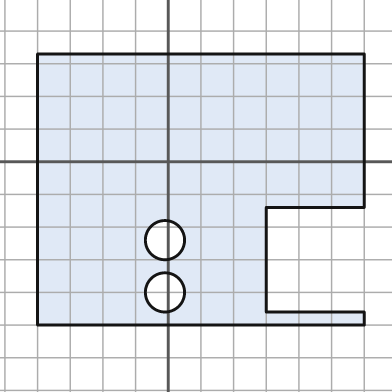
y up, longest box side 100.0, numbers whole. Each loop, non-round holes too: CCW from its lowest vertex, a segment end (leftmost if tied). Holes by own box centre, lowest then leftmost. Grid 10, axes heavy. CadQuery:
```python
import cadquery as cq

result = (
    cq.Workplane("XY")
    .moveTo(-40.0, -50.0)
    .lineTo(60.0, -50.0)
    .lineTo(60.0, -46.0)
    .lineTo(30.0, -46.0)
    .lineTo(30.0, -14.0)
    .lineTo(60.0, -14.0)
    .lineTo(60.0, 33.0)
    .lineTo(-40.0, 33.0)
    .close()
    .moveTo(-1.0, -40.0)
    .circle(6.0)
    .moveTo(-1.0, -24.0)
    .circle(6.0)
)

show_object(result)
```